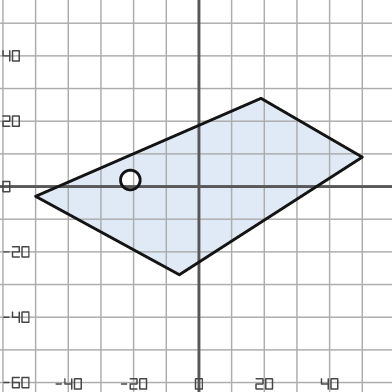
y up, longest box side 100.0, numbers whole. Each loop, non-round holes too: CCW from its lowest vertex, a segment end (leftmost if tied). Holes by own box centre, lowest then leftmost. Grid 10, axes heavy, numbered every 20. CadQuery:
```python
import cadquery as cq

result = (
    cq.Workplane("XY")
    .moveTo(-6.0, -27.0)
    .lineTo(50.0, 9.0)
    .lineTo(19.0, 27.0)
    .lineTo(-50.0, -3.0)
    .close()
    .moveTo(-21.0, 2.0)
    .circle(3.0)
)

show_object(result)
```